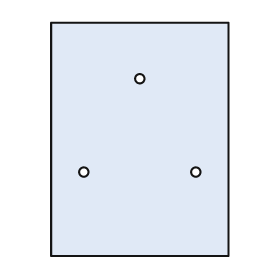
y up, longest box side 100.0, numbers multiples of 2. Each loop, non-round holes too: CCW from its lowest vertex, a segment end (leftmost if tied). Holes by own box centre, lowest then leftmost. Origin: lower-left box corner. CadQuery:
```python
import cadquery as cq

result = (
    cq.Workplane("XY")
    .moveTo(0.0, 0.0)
    .lineTo(76.0, 0.0)
    .lineTo(76.0, 100.0)
    .lineTo(0.0, 100.0)
    .close()
    .moveTo(14.0, 36.0)
    .circle(2.0)
    .moveTo(62.0, 36.0)
    .circle(2.0)
    .moveTo(38.0, 76.0)
    .circle(2.0)
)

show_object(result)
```